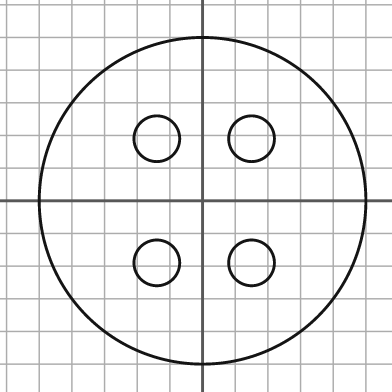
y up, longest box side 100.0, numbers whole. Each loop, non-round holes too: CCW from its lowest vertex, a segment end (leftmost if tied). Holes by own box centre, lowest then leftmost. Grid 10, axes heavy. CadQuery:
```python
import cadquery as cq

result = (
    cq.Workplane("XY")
    .moveTo(0.0, 0.0)
    .circle(50.0)
    .moveTo(-14.0, -19.0)
    .circle(7.0)
    .moveTo(15.0, -19.0)
    .circle(7.0)
    .moveTo(-14.0, 19.0)
    .circle(7.0)
    .moveTo(15.0, 19.0)
    .circle(7.0)
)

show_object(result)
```